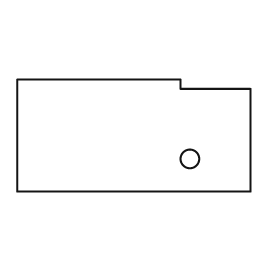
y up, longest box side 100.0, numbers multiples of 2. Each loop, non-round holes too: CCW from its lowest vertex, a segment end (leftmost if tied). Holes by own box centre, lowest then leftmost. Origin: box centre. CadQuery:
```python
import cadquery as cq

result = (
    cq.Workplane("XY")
    .moveTo(-50.0, -24.0)
    .lineTo(50.0, -24.0)
    .lineTo(50.0, 20.0)
    .lineTo(20.0, 20.0)
    .lineTo(20.0, 24.0)
    .lineTo(-50.0, 24.0)
    .close()
    .moveTo(24.0, -10.0)
    .circle(4.0)
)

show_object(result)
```